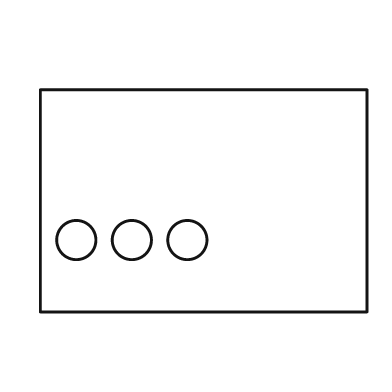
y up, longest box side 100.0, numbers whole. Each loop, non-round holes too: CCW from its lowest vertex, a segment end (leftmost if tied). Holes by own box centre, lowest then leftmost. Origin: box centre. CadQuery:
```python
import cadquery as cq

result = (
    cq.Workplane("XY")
    .moveTo(-50.0, -34.0)
    .lineTo(50.0, -34.0)
    .lineTo(50.0, 34.0)
    .lineTo(-50.0, 34.0)
    .close()
    .moveTo(-39.0, -12.0)
    .circle(6.0)
    .moveTo(-22.0, -12.0)
    .circle(6.0)
    .moveTo(-5.0, -12.0)
    .circle(6.0)
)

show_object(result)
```